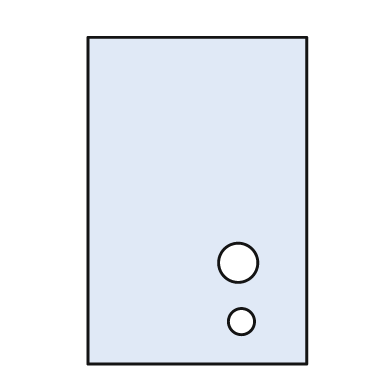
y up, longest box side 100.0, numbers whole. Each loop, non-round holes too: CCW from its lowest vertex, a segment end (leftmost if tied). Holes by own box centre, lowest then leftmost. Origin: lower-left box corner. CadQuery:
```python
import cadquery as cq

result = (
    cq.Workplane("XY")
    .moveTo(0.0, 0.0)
    .lineTo(67.0, 0.0)
    .lineTo(67.0, 100.0)
    .lineTo(0.0, 100.0)
    .close()
    .moveTo(47.0, 13.0)
    .circle(4.0)
    .moveTo(46.0, 31.0)
    .circle(6.0)
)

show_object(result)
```